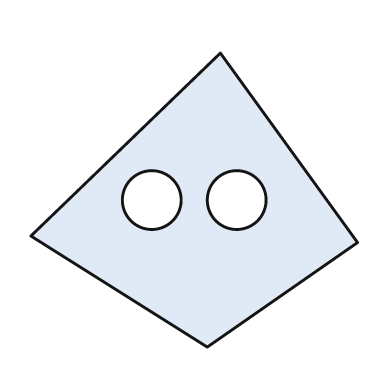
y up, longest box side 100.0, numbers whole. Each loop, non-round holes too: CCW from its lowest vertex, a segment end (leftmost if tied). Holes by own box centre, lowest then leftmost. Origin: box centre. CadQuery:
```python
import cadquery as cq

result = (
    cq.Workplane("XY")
    .moveTo(4.0, -45.0)
    .lineTo(50.0, -13.0)
    .lineTo(8.0, 45.0)
    .lineTo(-50.0, -11.0)
    .close()
    .moveTo(-13.0, 0.0)
    .circle(9.0)
    .moveTo(13.0, 0.0)
    .circle(9.0)
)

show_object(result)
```